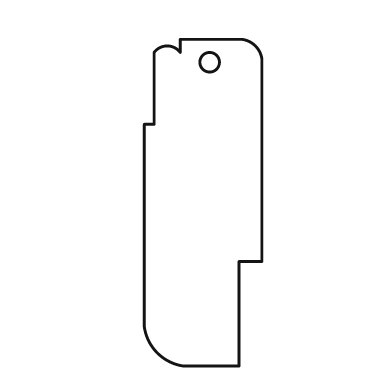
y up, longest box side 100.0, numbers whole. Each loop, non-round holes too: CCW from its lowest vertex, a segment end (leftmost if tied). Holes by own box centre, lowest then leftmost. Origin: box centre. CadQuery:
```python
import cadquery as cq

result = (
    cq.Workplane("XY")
    .moveTo(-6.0, -50.0)
    .lineTo(11.0, -50.0)
    .lineTo(11.0, -18.0)
    .lineTo(18.0, -18.0)
    .lineTo(18.0, 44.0)
    .threePointArc((16.0, 48.0), (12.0, 50.0))
    .lineTo(-7.0, 50.0)
    .lineTo(-7.0, 46.0)
    .threePointArc((-11.0, 48.0), (-15.0, 46.0))
    .lineTo(-15.0, 24.0)
    .lineTo(-18.0, 24.0)
    .lineTo(-18.0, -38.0)
    .threePointArc((-14.0, -46.0), (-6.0, -50.0))
    .close()
    .moveTo(2.0, 43.0)
    .circle(3.0)
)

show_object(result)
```